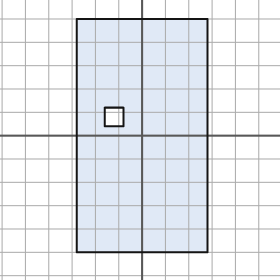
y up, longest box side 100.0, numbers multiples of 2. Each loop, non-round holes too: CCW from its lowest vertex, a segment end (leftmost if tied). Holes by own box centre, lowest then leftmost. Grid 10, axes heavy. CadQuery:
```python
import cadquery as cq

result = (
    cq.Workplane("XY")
    .moveTo(-28.0, -50.0)
    .lineTo(28.0, -50.0)
    .lineTo(28.0, 50.0)
    .lineTo(-28.0, 50.0)
    .close()
    .moveTo(-16.0, 4.0)
    .lineTo(-8.0, 4.0)
    .lineTo(-8.0, 12.0)
    .lineTo(-16.0, 12.0)
    .close()
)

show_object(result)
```